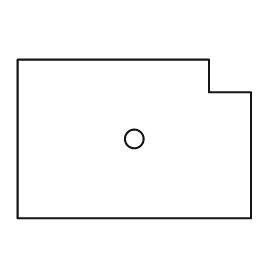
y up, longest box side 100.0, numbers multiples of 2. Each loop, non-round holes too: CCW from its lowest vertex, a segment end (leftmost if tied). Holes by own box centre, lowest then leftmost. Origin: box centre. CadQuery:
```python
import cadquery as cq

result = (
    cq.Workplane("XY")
    .moveTo(-50.0, -34.0)
    .lineTo(50.0, -34.0)
    .lineTo(50.0, 20.0)
    .lineTo(32.0, 20.0)
    .lineTo(32.0, 34.0)
    .lineTo(-50.0, 34.0)
    .close()
    .moveTo(0.0, 0.0)
    .circle(4.0)
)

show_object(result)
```